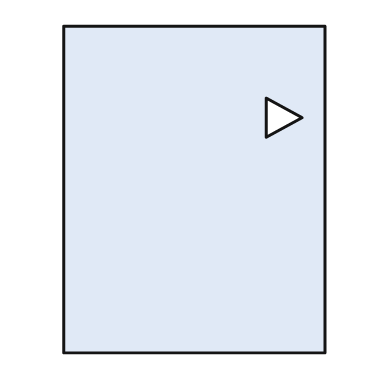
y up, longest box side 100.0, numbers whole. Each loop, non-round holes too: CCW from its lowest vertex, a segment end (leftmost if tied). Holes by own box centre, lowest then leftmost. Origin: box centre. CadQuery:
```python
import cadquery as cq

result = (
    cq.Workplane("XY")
    .moveTo(-40.0, -50.0)
    .lineTo(40.0, -50.0)
    .lineTo(40.0, 50.0)
    .lineTo(-40.0, 50.0)
    .close()
    .moveTo(22.0, 16.0)
    .lineTo(33.0, 22.0)
    .lineTo(22.0, 28.0)
    .close()
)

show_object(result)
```